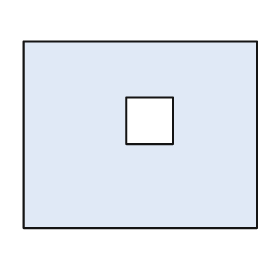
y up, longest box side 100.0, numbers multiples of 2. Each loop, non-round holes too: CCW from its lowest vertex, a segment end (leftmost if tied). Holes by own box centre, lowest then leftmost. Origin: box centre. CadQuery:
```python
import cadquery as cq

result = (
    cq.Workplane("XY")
    .moveTo(-50.0, -40.0)
    .lineTo(50.0, -40.0)
    .lineTo(50.0, 40.0)
    .lineTo(-50.0, 40.0)
    .close()
    .moveTo(-6.0, -4.0)
    .lineTo(14.0, -4.0)
    .lineTo(14.0, 16.0)
    .lineTo(-6.0, 16.0)
    .close()
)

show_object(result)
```